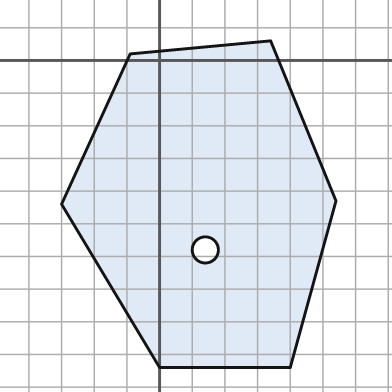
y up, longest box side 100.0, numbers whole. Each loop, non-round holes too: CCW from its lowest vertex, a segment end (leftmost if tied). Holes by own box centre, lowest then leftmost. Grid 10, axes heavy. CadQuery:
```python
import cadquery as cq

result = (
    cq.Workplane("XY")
    .moveTo(0.0, -94.0)
    .lineTo(40.0, -94.0)
    .lineTo(54.0, -43.0)
    .lineTo(34.0, 6.0)
    .lineTo(-9.0, 2.0)
    .lineTo(-30.0, -44.0)
    .close()
    .moveTo(14.0, -58.0)
    .circle(4.0)
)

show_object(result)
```